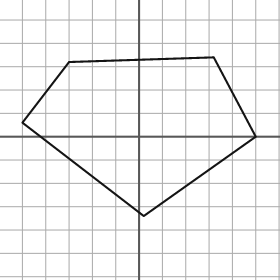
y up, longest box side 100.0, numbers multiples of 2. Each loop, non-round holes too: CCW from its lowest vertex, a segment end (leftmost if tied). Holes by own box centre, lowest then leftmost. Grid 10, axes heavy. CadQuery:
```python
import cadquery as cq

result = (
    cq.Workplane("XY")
    .moveTo(2.0, -34.0)
    .lineTo(50.0, 0.0)
    .lineTo(32.0, 34.0)
    .lineTo(-30.0, 32.0)
    .lineTo(-50.0, 6.0)
    .close()
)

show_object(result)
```